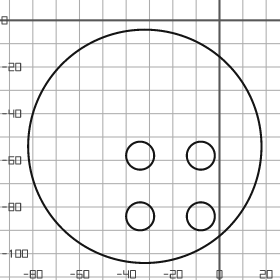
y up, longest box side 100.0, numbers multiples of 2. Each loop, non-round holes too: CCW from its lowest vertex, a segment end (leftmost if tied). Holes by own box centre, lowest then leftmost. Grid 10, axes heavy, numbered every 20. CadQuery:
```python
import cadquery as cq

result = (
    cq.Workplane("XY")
    .moveTo(-32.0, -54.0)
    .circle(50.0)
    .moveTo(-34.0, -84.0)
    .circle(6.0)
    .moveTo(-8.0, -84.0)
    .circle(6.0)
    .moveTo(-34.0, -58.0)
    .circle(6.0)
    .moveTo(-8.0, -58.0)
    .circle(6.0)
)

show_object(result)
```